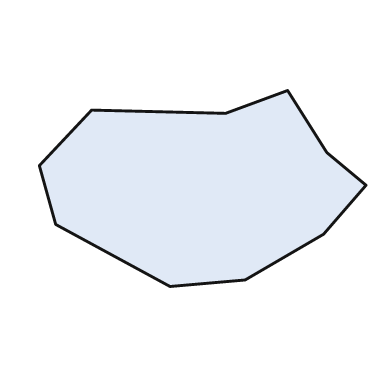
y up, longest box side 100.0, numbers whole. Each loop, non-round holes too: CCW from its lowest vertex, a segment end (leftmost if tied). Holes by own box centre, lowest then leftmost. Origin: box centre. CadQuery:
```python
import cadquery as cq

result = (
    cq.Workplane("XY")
    .moveTo(-10.0, -30.0)
    .lineTo(13.0, -28.0)
    .lineTo(37.0, -14.0)
    .lineTo(50.0, 1.0)
    .lineTo(38.0, 11.0)
    .lineTo(26.0, 30.0)
    .lineTo(7.0, 23.0)
    .lineTo(-34.0, 24.0)
    .lineTo(-50.0, 7.0)
    .lineTo(-45.0, -11.0)
    .close()
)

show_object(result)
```